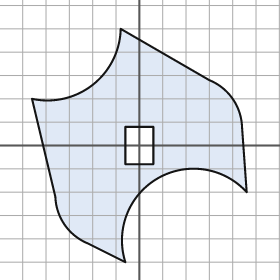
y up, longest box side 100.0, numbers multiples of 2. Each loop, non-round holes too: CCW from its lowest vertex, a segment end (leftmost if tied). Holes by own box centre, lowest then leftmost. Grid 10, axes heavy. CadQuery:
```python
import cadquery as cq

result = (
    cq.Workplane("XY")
    .moveTo(-6.0, -50.0)
    .threePointArc((8.0, -14.0), (46.0, -20.0))
    .lineTo(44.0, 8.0)
    .threePointArc((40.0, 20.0), (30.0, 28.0))
    .lineTo(-8.0, 50.0)
    .threePointArc((-20.0, 26.0), (-46.0, 20.0))
    .lineTo(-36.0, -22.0)
    .threePointArc((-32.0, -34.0), (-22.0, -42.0))
    .close()
    .moveTo(-6.0, -8.0)
    .lineTo(6.0, -8.0)
    .lineTo(6.0, 8.0)
    .lineTo(-6.0, 8.0)
    .close()
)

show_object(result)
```